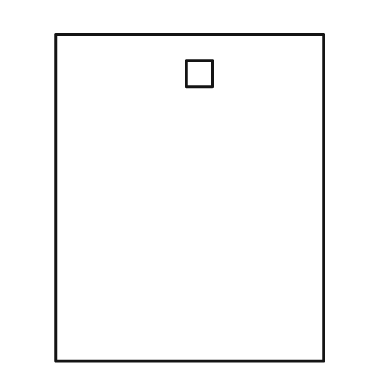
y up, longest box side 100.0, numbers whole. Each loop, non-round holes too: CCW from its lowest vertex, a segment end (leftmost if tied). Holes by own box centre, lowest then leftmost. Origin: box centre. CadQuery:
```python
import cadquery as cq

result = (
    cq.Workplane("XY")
    .moveTo(-41.0, -50.0)
    .lineTo(41.0, -50.0)
    .lineTo(41.0, 50.0)
    .lineTo(-41.0, 50.0)
    .close()
    .moveTo(-1.0, 34.0)
    .lineTo(7.0, 34.0)
    .lineTo(7.0, 42.0)
    .lineTo(-1.0, 42.0)
    .close()
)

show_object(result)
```